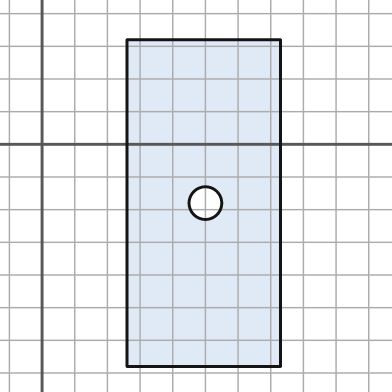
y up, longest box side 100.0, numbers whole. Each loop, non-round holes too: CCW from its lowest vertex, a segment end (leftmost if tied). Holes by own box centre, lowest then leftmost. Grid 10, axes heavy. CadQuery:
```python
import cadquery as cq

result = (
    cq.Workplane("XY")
    .moveTo(26.0, -68.0)
    .lineTo(73.0, -68.0)
    .lineTo(73.0, 32.0)
    .lineTo(26.0, 32.0)
    .close()
    .moveTo(50.0, -18.0)
    .circle(5.0)
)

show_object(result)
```